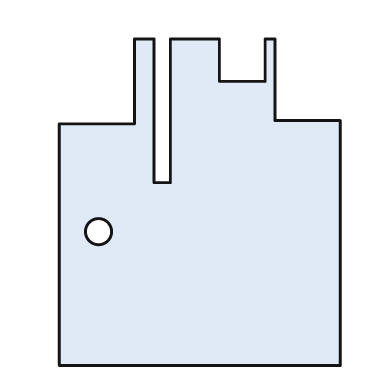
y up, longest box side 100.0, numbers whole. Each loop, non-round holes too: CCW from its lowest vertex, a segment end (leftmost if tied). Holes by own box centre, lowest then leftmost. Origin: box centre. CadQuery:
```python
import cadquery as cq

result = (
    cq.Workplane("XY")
    .moveTo(-43.0, -50.0)
    .lineTo(43.0, -50.0)
    .lineTo(43.0, 25.0)
    .lineTo(23.0, 25.0)
    .lineTo(23.0, 50.0)
    .lineTo(20.0, 50.0)
    .lineTo(20.0, 37.0)
    .lineTo(6.0, 37.0)
    .lineTo(6.0, 50.0)
    .lineTo(-9.0, 50.0)
    .lineTo(-9.0, 6.0)
    .lineTo(-14.0, 6.0)
    .lineTo(-14.0, 50.0)
    .lineTo(-20.0, 50.0)
    .lineTo(-20.0, 24.0)
    .lineTo(-43.0, 24.0)
    .close()
    .moveTo(-31.0, -9.0)
    .circle(4.0)
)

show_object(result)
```